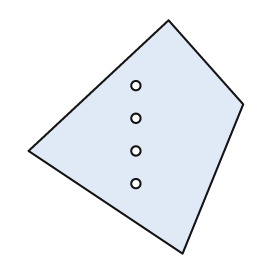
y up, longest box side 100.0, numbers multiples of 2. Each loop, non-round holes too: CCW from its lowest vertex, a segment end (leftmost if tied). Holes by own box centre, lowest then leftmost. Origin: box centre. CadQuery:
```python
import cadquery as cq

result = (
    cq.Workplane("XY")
    .moveTo(20.0, -50.0)
    .lineTo(46.0, 14.0)
    .lineTo(14.0, 50.0)
    .lineTo(-46.0, -6.0)
    .close()
    .moveTo(0.0, -20.0)
    .circle(2.0)
    .moveTo(0.0, -6.0)
    .circle(2.0)
    .moveTo(0.0, 8.0)
    .circle(2.0)
    .moveTo(0.0, 22.0)
    .circle(2.0)
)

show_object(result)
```